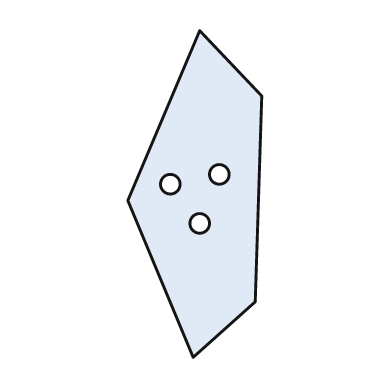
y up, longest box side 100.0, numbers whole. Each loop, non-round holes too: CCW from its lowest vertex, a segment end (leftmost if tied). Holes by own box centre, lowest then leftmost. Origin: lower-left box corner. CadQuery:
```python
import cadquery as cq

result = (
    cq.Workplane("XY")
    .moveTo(20.0, 0.0)
    .lineTo(39.0, 17.0)
    .lineTo(41.0, 80.0)
    .lineTo(22.0, 100.0)
    .lineTo(0.0, 48.0)
    .close()
    .moveTo(22.0, 41.0)
    .circle(3.0)
    .moveTo(13.0, 53.0)
    .circle(3.0)
    .moveTo(28.0, 56.0)
    .circle(3.0)
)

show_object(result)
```